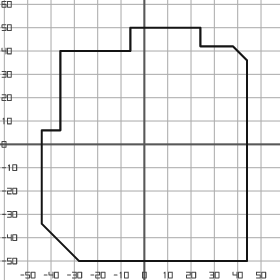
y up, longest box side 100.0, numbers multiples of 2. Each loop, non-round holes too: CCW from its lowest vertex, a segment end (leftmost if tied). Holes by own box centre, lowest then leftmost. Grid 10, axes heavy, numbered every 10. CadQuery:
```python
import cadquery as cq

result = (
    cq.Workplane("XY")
    .moveTo(-28.0, -50.0)
    .lineTo(44.0, -50.0)
    .lineTo(44.0, 36.0)
    .lineTo(38.0, 42.0)
    .lineTo(24.0, 42.0)
    .lineTo(24.0, 50.0)
    .lineTo(-6.0, 50.0)
    .lineTo(-6.0, 40.0)
    .lineTo(-36.0, 40.0)
    .lineTo(-36.0, 6.0)
    .lineTo(-44.0, 6.0)
    .lineTo(-44.0, -34.0)
    .close()
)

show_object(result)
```